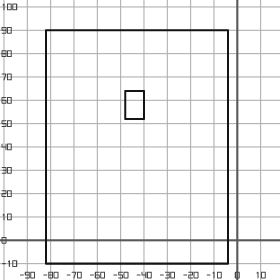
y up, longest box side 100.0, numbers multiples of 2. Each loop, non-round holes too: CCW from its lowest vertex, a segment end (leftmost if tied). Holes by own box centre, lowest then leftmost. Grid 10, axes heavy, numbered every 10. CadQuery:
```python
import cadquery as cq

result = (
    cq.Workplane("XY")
    .moveTo(-82.0, -10.0)
    .lineTo(-4.0, -10.0)
    .lineTo(-4.0, 90.0)
    .lineTo(-82.0, 90.0)
    .close()
    .moveTo(-48.0, 52.0)
    .lineTo(-40.0, 52.0)
    .lineTo(-40.0, 64.0)
    .lineTo(-48.0, 64.0)
    .close()
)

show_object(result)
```